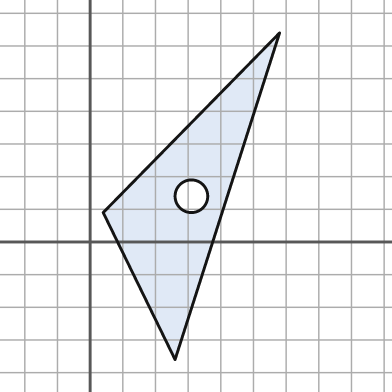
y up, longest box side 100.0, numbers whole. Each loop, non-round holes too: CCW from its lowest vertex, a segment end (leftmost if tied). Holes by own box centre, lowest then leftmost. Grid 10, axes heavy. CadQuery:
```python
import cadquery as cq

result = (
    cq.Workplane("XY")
    .moveTo(26.0, -36.0)
    .lineTo(58.0, 64.0)
    .lineTo(4.0, 9.0)
    .close()
    .moveTo(31.0, 14.0)
    .circle(5.0)
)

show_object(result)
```